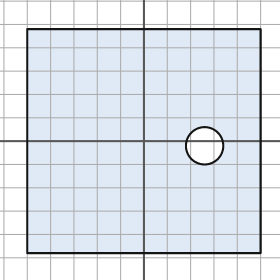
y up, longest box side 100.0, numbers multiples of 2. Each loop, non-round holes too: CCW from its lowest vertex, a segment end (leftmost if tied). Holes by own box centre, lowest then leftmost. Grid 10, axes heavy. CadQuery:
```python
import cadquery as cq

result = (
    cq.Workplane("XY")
    .moveTo(-50.0, -48.0)
    .lineTo(50.0, -48.0)
    .lineTo(50.0, 48.0)
    .lineTo(-50.0, 48.0)
    .close()
    .moveTo(26.0, -2.0)
    .circle(8.0)
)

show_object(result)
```